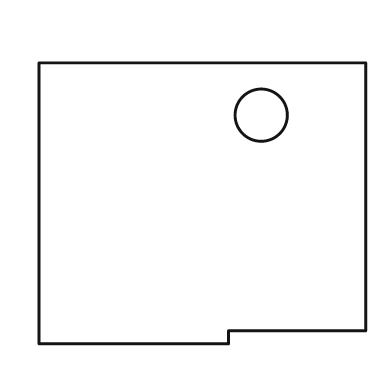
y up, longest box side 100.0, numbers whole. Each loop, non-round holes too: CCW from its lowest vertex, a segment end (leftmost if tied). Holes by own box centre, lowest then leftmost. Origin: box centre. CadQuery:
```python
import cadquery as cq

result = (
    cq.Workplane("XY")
    .moveTo(-50.0, -43.0)
    .lineTo(8.0, -43.0)
    .lineTo(8.0, -39.0)
    .lineTo(50.0, -39.0)
    .lineTo(50.0, 43.0)
    .lineTo(-50.0, 43.0)
    .close()
    .moveTo(18.0, 27.0)
    .circle(8.0)
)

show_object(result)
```